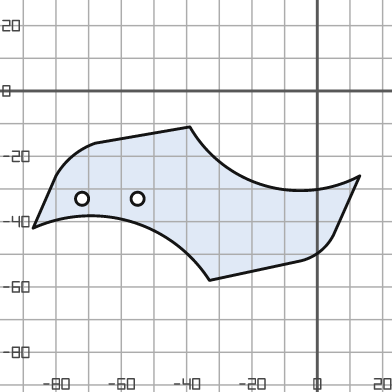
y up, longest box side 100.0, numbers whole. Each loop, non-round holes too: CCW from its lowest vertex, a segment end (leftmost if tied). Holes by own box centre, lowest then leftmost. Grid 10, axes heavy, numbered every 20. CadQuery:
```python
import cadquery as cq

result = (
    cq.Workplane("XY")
    .moveTo(-33.0, -58.0)
    .lineTo(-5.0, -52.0)
    .threePointArc((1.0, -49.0), (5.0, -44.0))
    .lineTo(13.0, -26.0)
    .threePointArc((-16.0, -29.0), (-39.0, -11.0))
    .lineTo(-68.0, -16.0)
    .threePointArc((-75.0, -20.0), (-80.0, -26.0))
    .lineTo(-87.0, -42.0)
    .threePointArc((-57.0, -40.0), (-33.0, -58.0))
    .close()
    .moveTo(-72.0, -33.0)
    .circle(2.0)
    .moveTo(-55.0, -33.0)
    .circle(2.0)
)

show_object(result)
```